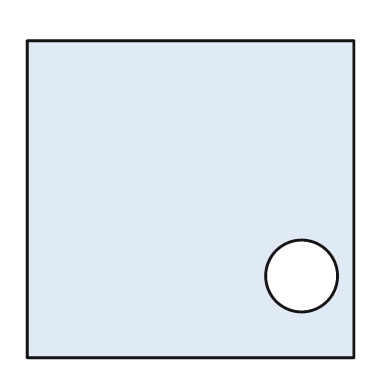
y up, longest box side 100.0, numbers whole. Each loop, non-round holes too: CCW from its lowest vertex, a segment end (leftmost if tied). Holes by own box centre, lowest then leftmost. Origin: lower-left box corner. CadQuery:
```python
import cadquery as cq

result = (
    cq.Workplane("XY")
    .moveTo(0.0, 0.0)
    .lineTo(100.0, 0.0)
    .lineTo(100.0, 97.0)
    .lineTo(0.0, 97.0)
    .close()
    .moveTo(84.0, 25.0)
    .circle(11.0)
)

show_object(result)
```